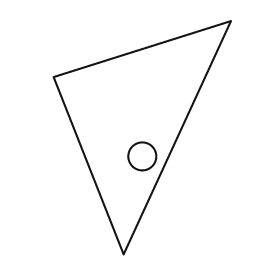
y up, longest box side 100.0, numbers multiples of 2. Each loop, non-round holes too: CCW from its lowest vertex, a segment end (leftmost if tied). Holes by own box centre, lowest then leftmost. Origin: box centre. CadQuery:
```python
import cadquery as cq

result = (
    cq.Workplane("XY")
    .moveTo(-8.0, -50.0)
    .lineTo(38.0, 50.0)
    .lineTo(-38.0, 26.0)
    .close()
    .moveTo(0.0, -8.0)
    .circle(6.0)
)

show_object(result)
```